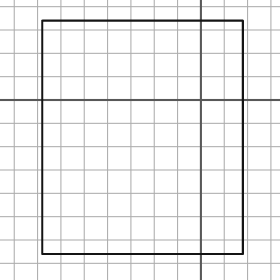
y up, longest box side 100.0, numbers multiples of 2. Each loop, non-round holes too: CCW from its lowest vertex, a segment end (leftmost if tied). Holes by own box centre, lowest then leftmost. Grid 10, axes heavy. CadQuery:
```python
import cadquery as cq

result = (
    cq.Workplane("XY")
    .moveTo(-68.0, -66.0)
    .lineTo(18.0, -66.0)
    .lineTo(18.0, 34.0)
    .lineTo(-68.0, 34.0)
    .close()
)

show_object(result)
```